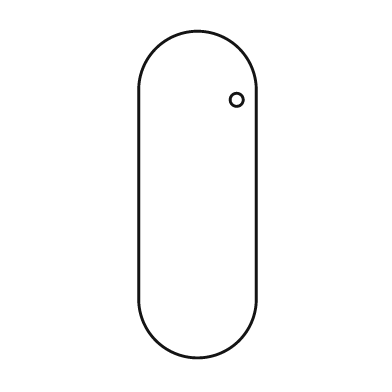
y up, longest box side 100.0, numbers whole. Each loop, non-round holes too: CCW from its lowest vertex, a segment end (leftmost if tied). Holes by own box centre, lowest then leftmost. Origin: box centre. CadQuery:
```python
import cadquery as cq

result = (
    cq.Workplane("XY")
    .moveTo(-18.0, -32.0)
    .threePointArc((0.0, -50.0), (18.0, -32.0))
    .lineTo(18.0, 32.0)
    .threePointArc((0.0, 50.0), (-18.0, 32.0))
    .close()
    .moveTo(12.0, 29.0)
    .circle(2.0)
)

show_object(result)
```